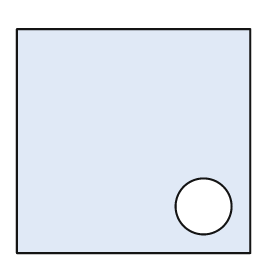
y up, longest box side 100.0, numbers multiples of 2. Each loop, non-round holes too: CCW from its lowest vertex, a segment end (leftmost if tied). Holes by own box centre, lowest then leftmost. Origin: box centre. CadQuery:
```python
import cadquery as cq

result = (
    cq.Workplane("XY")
    .moveTo(-50.0, -48.0)
    .lineTo(50.0, -48.0)
    .lineTo(50.0, 48.0)
    .lineTo(-50.0, 48.0)
    .close()
    .moveTo(30.0, -28.0)
    .circle(12.0)
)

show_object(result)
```